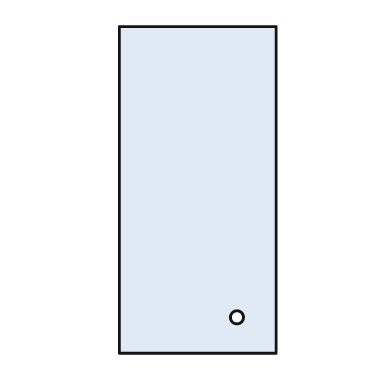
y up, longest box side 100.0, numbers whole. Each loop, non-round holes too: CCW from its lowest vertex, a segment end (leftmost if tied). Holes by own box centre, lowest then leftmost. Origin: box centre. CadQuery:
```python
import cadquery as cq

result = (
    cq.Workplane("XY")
    .moveTo(-24.0, -50.0)
    .lineTo(24.0, -50.0)
    .lineTo(24.0, 50.0)
    .lineTo(-24.0, 50.0)
    .close()
    .moveTo(12.0, -39.0)
    .circle(2.0)
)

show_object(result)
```